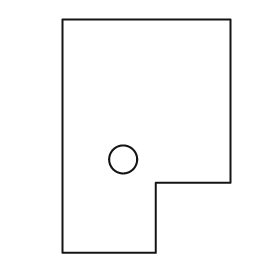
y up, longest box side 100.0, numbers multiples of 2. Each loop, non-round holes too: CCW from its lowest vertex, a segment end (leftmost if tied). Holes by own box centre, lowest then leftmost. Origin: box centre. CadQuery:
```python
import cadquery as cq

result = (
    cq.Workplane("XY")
    .moveTo(-36.0, -50.0)
    .lineTo(4.0, -50.0)
    .lineTo(4.0, -20.0)
    .lineTo(36.0, -20.0)
    .lineTo(36.0, 50.0)
    .lineTo(-36.0, 50.0)
    .close()
    .moveTo(-10.0, -10.0)
    .circle(6.0)
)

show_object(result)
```